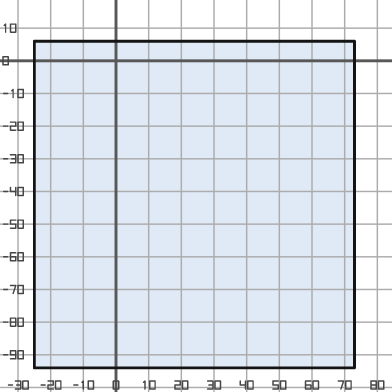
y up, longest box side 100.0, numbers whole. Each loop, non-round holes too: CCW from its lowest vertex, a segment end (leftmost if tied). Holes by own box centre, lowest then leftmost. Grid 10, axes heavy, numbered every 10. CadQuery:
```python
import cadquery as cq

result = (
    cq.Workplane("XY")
    .moveTo(-25.0, -94.0)
    .lineTo(73.0, -94.0)
    .lineTo(73.0, 6.0)
    .lineTo(-25.0, 6.0)
    .close()
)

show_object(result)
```